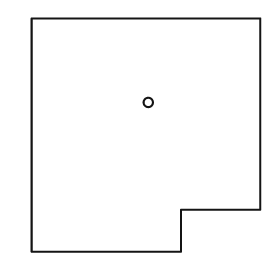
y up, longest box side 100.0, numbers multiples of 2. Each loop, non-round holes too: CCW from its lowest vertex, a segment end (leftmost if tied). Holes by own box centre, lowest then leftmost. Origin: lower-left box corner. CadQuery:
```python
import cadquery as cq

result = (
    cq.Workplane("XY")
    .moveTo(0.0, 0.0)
    .lineTo(64.0, 0.0)
    .lineTo(64.0, 18.0)
    .lineTo(98.0, 18.0)
    .lineTo(98.0, 100.0)
    .lineTo(0.0, 100.0)
    .close()
    .moveTo(50.0, 64.0)
    .circle(2.0)
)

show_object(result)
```